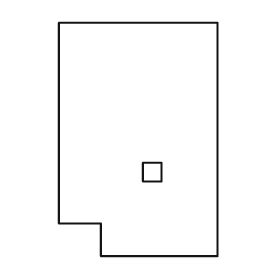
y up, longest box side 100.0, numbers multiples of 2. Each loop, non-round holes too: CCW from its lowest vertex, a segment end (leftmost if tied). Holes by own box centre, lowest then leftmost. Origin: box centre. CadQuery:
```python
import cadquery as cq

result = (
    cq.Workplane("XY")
    .moveTo(-16.0, -50.0)
    .lineTo(34.0, -50.0)
    .lineTo(34.0, 50.0)
    .lineTo(-34.0, 50.0)
    .lineTo(-34.0, -36.0)
    .lineTo(-16.0, -36.0)
    .close()
    .moveTo(2.0, -18.0)
    .lineTo(10.0, -18.0)
    .lineTo(10.0, -10.0)
    .lineTo(2.0, -10.0)
    .close()
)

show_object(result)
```